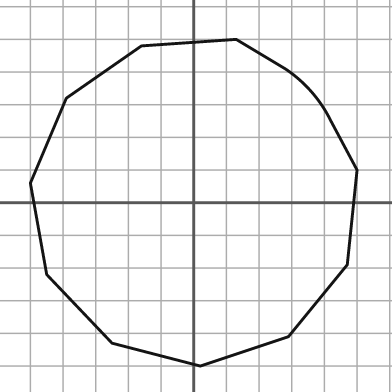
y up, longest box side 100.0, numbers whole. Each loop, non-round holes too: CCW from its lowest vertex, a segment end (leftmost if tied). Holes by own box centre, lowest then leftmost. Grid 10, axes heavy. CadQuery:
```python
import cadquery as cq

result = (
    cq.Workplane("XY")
    .moveTo(2.0, -50.0)
    .lineTo(29.0, -41.0)
    .lineTo(47.0, -19.0)
    .lineTo(50.0, 10.0)
    .lineTo(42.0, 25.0)
    .threePointArc((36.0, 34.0), (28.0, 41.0))
    .lineTo(13.0, 50.0)
    .lineTo(-16.0, 48.0)
    .lineTo(-39.0, 32.0)
    .lineTo(-50.0, 6.0)
    .lineTo(-45.0, -22.0)
    .lineTo(-25.0, -43.0)
    .close()
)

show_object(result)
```